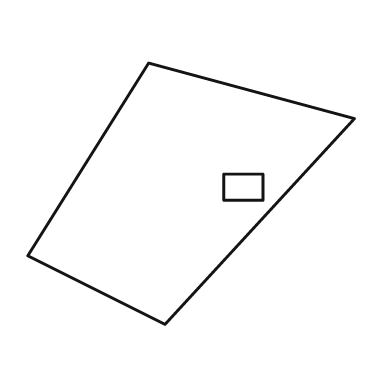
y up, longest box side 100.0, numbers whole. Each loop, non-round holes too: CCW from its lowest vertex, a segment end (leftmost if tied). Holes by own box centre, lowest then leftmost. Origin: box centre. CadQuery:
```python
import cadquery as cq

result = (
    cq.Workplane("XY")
    .moveTo(-8.0, -40.0)
    .lineTo(50.0, 23.0)
    .lineTo(-13.0, 40.0)
    .lineTo(-50.0, -19.0)
    .close()
    .moveTo(10.0, -2.0)
    .lineTo(22.0, -2.0)
    .lineTo(22.0, 6.0)
    .lineTo(10.0, 6.0)
    .close()
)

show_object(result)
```